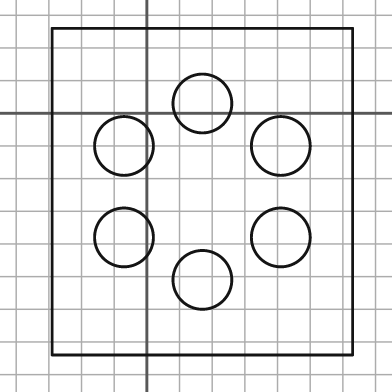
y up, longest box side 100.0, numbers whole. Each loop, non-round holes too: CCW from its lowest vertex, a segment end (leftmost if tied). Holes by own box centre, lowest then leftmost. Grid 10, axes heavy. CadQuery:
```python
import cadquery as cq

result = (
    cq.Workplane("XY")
    .moveTo(-29.0, -74.0)
    .lineTo(63.0, -74.0)
    .lineTo(63.0, 26.0)
    .lineTo(-29.0, 26.0)
    .close()
    .moveTo(17.0, -51.0)
    .circle(9.0)
    .moveTo(-7.0, -38.0)
    .circle(9.0)
    .moveTo(41.0, -38.0)
    .circle(9.0)
    .moveTo(-7.0, -10.0)
    .circle(9.0)
    .moveTo(41.0, -10.0)
    .circle(9.0)
    .moveTo(17.0, 3.0)
    .circle(9.0)
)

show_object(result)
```